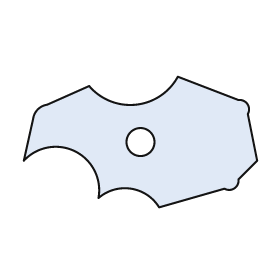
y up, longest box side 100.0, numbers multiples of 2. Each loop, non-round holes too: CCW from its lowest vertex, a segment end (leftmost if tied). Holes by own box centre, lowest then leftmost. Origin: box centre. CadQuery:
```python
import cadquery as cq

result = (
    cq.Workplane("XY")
    .moveTo(8.0, -28.0)
    .lineTo(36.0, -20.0)
    .threePointArc((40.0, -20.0), (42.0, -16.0))
    .lineTo(50.0, -8.0)
    .lineTo(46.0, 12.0)
    .threePointArc((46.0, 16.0), (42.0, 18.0))
    .lineTo(16.0, 28.0)
    .threePointArc((-2.0, 16.0), (-22.0, 24.0))
    .lineTo(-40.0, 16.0)
    .threePointArc((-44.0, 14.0), (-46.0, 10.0))
    .lineTo(-50.0, -8.0)
    .threePointArc((-28.0, -4.0), (-18.0, -24.0))
    .threePointArc((-4.0, -20.0), (8.0, -28.0))
    .close()
    .moveTo(0.0, 0.0)
    .circle(6.0)
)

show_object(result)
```